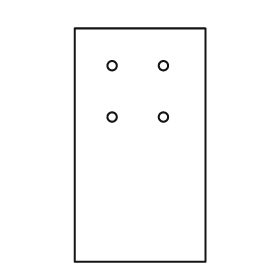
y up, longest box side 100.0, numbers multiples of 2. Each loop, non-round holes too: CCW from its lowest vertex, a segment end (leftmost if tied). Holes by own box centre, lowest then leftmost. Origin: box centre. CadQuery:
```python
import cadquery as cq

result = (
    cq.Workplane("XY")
    .moveTo(-28.0, -50.0)
    .lineTo(28.0, -50.0)
    .lineTo(28.0, 50.0)
    .lineTo(-28.0, 50.0)
    .close()
    .moveTo(-12.0, 12.0)
    .circle(2.0)
    .moveTo(10.0, 12.0)
    .circle(2.0)
    .moveTo(-12.0, 34.0)
    .circle(2.0)
    .moveTo(10.0, 34.0)
    .circle(2.0)
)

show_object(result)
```